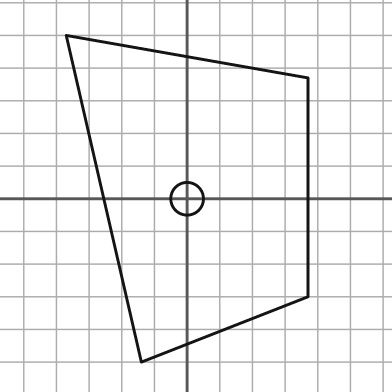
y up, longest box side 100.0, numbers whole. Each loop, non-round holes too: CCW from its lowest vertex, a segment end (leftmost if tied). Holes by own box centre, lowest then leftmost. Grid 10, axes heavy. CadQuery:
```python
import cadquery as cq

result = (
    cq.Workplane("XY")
    .moveTo(-14.0, -50.0)
    .lineTo(37.0, -30.0)
    .lineTo(37.0, 37.0)
    .lineTo(-37.0, 50.0)
    .close()
    .moveTo(0.0, 0.0)
    .circle(5.0)
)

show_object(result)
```